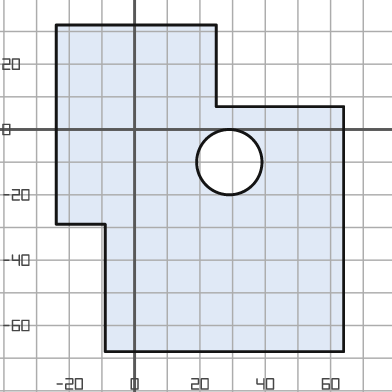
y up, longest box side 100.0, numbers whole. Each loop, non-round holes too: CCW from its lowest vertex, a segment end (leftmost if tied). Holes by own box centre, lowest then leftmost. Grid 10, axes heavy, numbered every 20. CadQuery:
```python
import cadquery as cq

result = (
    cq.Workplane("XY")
    .moveTo(-9.0, -68.0)
    .lineTo(64.0, -68.0)
    .lineTo(64.0, 7.0)
    .lineTo(25.0, 7.0)
    .lineTo(25.0, 32.0)
    .lineTo(-24.0, 32.0)
    .lineTo(-24.0, -29.0)
    .lineTo(-9.0, -29.0)
    .close()
    .moveTo(29.0, -10.0)
    .circle(10.0)
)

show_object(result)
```